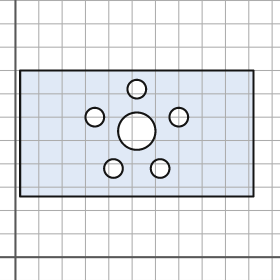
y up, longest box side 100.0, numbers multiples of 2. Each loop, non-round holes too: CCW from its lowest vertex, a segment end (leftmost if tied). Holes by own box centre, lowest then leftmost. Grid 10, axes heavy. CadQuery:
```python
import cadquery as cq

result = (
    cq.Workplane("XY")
    .moveTo(2.0, 26.0)
    .lineTo(102.0, 26.0)
    .lineTo(102.0, 80.0)
    .lineTo(2.0, 80.0)
    .close()
    .moveTo(42.0, 38.0)
    .circle(4.0)
    .moveTo(62.0, 38.0)
    .circle(4.0)
    .moveTo(52.0, 54.0)
    .circle(8.0)
    .moveTo(34.0, 60.0)
    .circle(4.0)
    .moveTo(70.0, 60.0)
    .circle(4.0)
    .moveTo(52.0, 72.0)
    .circle(4.0)
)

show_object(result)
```